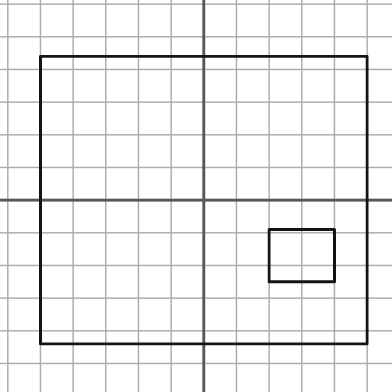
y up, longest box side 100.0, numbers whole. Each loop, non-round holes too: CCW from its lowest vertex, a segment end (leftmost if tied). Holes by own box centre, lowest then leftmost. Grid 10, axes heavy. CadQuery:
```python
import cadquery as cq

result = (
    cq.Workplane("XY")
    .moveTo(-50.0, -44.0)
    .lineTo(50.0, -44.0)
    .lineTo(50.0, 44.0)
    .lineTo(-50.0, 44.0)
    .close()
    .moveTo(20.0, -25.0)
    .lineTo(40.0, -25.0)
    .lineTo(40.0, -9.0)
    .lineTo(20.0, -9.0)
    .close()
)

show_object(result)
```